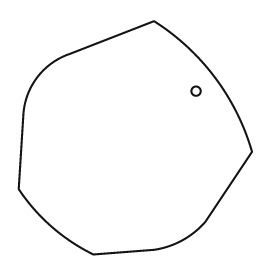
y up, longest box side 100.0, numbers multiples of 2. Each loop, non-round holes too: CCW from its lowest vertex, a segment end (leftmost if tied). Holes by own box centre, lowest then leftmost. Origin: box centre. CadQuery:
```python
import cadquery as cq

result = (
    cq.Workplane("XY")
    .moveTo(-18.0, -50.0)
    .lineTo(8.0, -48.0)
    .threePointArc((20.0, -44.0), (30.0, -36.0))
    .lineTo(50.0, -6.0)
    .threePointArc((34.0, 26.0), (8.0, 50.0))
    .lineTo(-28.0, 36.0)
    .threePointArc((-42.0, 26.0), (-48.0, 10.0))
    .lineTo(-50.0, -22.0)
    .threePointArc((-36.0, -38.0), (-18.0, -50.0))
    .close()
    .moveTo(26.0, 20.0)
    .circle(2.0)
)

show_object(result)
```